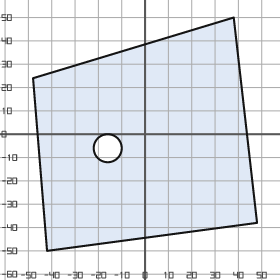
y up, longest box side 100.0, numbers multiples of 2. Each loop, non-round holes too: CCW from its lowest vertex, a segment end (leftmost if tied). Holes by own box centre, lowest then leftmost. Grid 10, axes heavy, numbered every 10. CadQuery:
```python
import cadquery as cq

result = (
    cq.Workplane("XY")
    .moveTo(-42.0, -50.0)
    .lineTo(48.0, -38.0)
    .lineTo(38.0, 50.0)
    .lineTo(-48.0, 24.0)
    .close()
    .moveTo(-16.0, -6.0)
    .circle(6.0)
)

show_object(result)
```